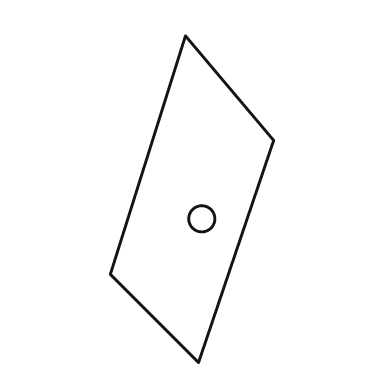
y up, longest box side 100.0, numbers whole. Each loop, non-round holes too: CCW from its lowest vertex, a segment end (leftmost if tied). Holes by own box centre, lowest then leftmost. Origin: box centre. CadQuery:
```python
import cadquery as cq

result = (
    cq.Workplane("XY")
    .moveTo(2.0, -50.0)
    .lineTo(25.0, 18.0)
    .lineTo(-2.0, 50.0)
    .lineTo(-25.0, -23.0)
    .close()
    .moveTo(3.0, -6.0)
    .circle(4.0)
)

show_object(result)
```